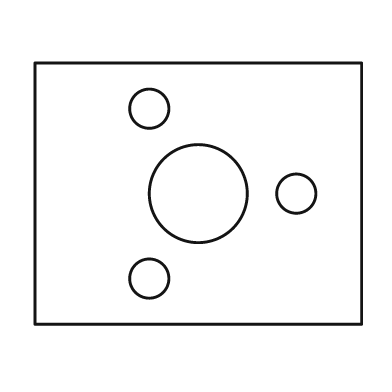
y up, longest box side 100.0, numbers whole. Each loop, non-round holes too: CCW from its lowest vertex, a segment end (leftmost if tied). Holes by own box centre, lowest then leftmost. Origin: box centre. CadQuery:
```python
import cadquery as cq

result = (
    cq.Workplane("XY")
    .moveTo(-50.0, -40.0)
    .lineTo(50.0, -40.0)
    .lineTo(50.0, 40.0)
    .lineTo(-50.0, 40.0)
    .close()
    .moveTo(-15.0, -26.0)
    .circle(6.0)
    .moveTo(0.0, 0.0)
    .circle(15.0)
    .moveTo(30.0, 0.0)
    .circle(6.0)
    .moveTo(-15.0, 26.0)
    .circle(6.0)
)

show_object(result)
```